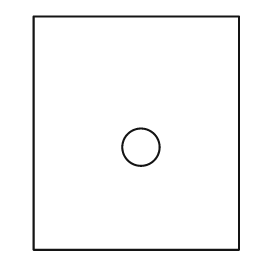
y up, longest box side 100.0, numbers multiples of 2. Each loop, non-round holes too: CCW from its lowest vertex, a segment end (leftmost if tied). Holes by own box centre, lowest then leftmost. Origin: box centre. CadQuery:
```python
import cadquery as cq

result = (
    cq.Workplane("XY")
    .moveTo(-44.0, -50.0)
    .lineTo(44.0, -50.0)
    .lineTo(44.0, 50.0)
    .lineTo(-44.0, 50.0)
    .close()
    .moveTo(2.0, -6.0)
    .circle(8.0)
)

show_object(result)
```